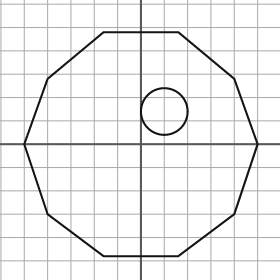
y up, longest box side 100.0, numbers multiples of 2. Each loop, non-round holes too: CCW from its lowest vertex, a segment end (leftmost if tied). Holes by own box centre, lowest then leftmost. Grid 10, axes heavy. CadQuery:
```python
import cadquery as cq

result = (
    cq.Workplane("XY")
    .moveTo(-16.0, -48.0)
    .lineTo(16.0, -48.0)
    .lineTo(40.0, -30.0)
    .lineTo(50.0, 0.0)
    .lineTo(40.0, 28.0)
    .lineTo(16.0, 48.0)
    .lineTo(-16.0, 48.0)
    .lineTo(-40.0, 28.0)
    .lineTo(-50.0, 0.0)
    .lineTo(-40.0, -30.0)
    .close()
    .moveTo(10.0, 14.0)
    .circle(10.0)
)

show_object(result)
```